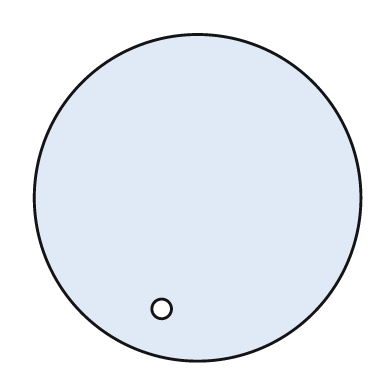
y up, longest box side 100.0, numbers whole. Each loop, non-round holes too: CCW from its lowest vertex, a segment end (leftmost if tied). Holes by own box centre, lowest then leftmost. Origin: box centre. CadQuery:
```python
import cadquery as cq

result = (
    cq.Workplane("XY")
    .moveTo(0.0, 0.0)
    .circle(50.0)
    .moveTo(-11.0, -34.0)
    .circle(3.0)
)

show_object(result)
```